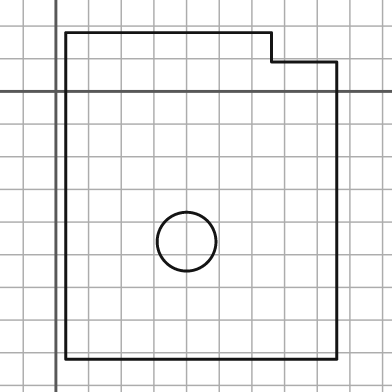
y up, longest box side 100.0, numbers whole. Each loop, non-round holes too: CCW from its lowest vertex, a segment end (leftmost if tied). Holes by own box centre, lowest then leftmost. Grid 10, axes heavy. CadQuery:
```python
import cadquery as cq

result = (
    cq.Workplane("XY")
    .moveTo(3.0, -82.0)
    .lineTo(86.0, -82.0)
    .lineTo(86.0, 9.0)
    .lineTo(66.0, 9.0)
    .lineTo(66.0, 18.0)
    .lineTo(3.0, 18.0)
    .close()
    .moveTo(40.0, -46.0)
    .circle(9.0)
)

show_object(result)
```